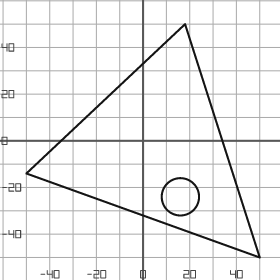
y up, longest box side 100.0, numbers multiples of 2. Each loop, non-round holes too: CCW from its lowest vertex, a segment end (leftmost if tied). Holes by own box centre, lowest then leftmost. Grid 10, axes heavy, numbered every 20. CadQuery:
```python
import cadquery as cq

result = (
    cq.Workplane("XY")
    .moveTo(50.0, -50.0)
    .lineTo(18.0, 50.0)
    .lineTo(-50.0, -14.0)
    .close()
    .moveTo(16.0, -24.0)
    .circle(8.0)
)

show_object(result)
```